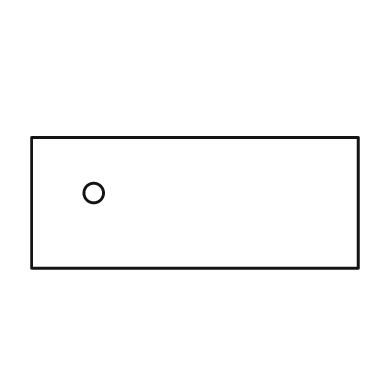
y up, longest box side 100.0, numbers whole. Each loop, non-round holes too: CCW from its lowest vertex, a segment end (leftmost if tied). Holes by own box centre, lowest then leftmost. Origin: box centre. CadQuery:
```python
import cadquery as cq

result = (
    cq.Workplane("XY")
    .moveTo(-50.0, -20.0)
    .lineTo(50.0, -20.0)
    .lineTo(50.0, 20.0)
    .lineTo(-50.0, 20.0)
    .close()
    .moveTo(-31.0, 3.0)
    .circle(3.0)
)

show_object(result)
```